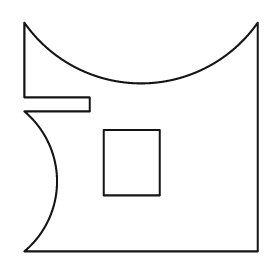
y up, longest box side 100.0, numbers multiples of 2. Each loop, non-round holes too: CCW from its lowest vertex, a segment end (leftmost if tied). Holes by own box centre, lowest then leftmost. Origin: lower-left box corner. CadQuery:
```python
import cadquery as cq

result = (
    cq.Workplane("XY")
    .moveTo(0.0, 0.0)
    .lineTo(100.0, 0.0)
    .lineTo(100.0, 98.0)
    .threePointArc((50.0, 72.0), (0.0, 98.0))
    .lineTo(0.0, 66.0)
    .lineTo(28.0, 66.0)
    .lineTo(28.0, 60.0)
    .lineTo(0.0, 60.0)
    .threePointArc((14.0, 30.0), (0.0, 0.0))
    .close()
    .moveTo(34.0, 24.0)
    .lineTo(58.0, 24.0)
    .lineTo(58.0, 52.0)
    .lineTo(34.0, 52.0)
    .close()
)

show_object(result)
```